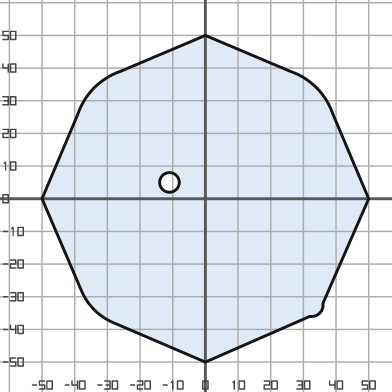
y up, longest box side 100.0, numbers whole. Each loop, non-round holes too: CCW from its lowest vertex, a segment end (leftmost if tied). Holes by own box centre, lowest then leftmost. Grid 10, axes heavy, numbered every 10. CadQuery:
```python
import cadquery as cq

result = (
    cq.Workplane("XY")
    .moveTo(0.0, -50.0)
    .lineTo(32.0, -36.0)
    .threePointArc((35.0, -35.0), (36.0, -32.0))
    .lineTo(50.0, 0.0)
    .lineTo(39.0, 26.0)
    .threePointArc((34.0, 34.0), (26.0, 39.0))
    .lineTo(0.0, 50.0)
    .lineTo(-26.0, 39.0)
    .threePointArc((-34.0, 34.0), (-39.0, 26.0))
    .lineTo(-50.0, 0.0)
    .lineTo(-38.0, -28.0)
    .threePointArc((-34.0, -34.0), (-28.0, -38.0))
    .close()
    .moveTo(-11.0, 5.0)
    .circle(3.0)
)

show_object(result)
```